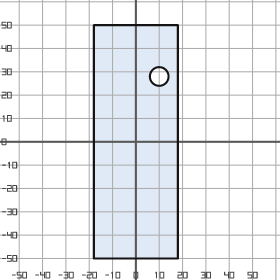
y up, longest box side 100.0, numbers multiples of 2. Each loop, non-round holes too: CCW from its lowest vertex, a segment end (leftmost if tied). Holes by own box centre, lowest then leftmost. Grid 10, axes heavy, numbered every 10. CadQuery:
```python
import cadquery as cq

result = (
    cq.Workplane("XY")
    .moveTo(-18.0, -50.0)
    .lineTo(18.0, -50.0)
    .lineTo(18.0, 50.0)
    .lineTo(-18.0, 50.0)
    .close()
    .moveTo(10.0, 28.0)
    .circle(4.0)
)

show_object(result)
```